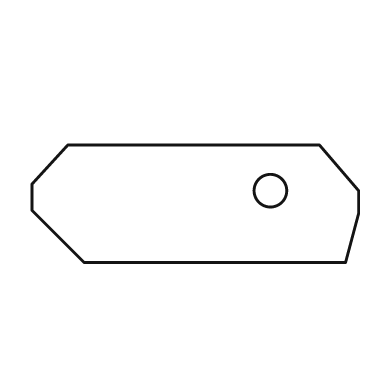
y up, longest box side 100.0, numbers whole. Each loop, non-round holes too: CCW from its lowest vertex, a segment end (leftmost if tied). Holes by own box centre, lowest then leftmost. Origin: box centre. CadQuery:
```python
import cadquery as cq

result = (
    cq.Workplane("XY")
    .moveTo(-34.0, -18.0)
    .lineTo(46.0, -18.0)
    .lineTo(50.0, -3.0)
    .lineTo(50.0, 4.0)
    .lineTo(38.0, 18.0)
    .lineTo(-39.0, 18.0)
    .lineTo(-50.0, 6.0)
    .lineTo(-50.0, -2.0)
    .close()
    .moveTo(23.0, 4.0)
    .circle(5.0)
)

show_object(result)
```